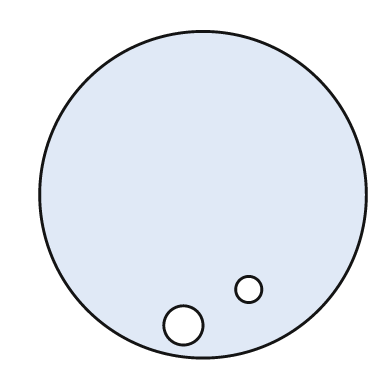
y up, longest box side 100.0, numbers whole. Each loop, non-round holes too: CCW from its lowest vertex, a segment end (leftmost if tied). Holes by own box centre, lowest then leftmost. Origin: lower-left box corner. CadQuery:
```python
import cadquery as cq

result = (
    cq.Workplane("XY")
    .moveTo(50.0, 50.0)
    .circle(50.0)
    .moveTo(44.0, 10.0)
    .circle(6.0)
    .moveTo(64.0, 21.0)
    .circle(4.0)
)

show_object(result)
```